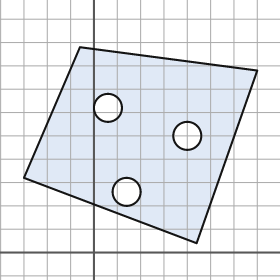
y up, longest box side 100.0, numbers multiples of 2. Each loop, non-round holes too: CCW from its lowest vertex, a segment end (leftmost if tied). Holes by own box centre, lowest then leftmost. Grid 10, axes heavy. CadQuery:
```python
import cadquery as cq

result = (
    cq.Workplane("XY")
    .moveTo(44.0, 4.0)
    .lineTo(70.0, 78.0)
    .lineTo(-6.0, 88.0)
    .lineTo(-30.0, 32.0)
    .close()
    .moveTo(14.0, 26.0)
    .circle(6.0)
    .moveTo(40.0, 50.0)
    .circle(6.0)
    .moveTo(6.0, 62.0)
    .circle(6.0)
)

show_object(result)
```